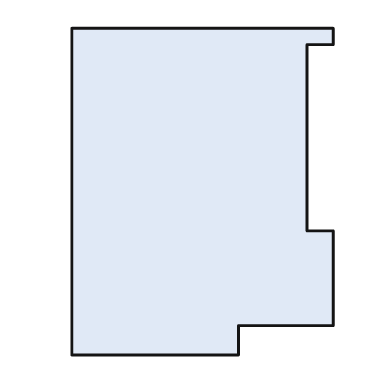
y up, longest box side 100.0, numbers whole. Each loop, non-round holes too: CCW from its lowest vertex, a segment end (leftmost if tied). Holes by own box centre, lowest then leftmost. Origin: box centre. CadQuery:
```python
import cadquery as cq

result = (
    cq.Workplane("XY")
    .moveTo(-40.0, -50.0)
    .lineTo(11.0, -50.0)
    .lineTo(11.0, -41.0)
    .lineTo(40.0, -41.0)
    .lineTo(40.0, -12.0)
    .lineTo(32.0, -12.0)
    .lineTo(32.0, 45.0)
    .lineTo(40.0, 45.0)
    .lineTo(40.0, 50.0)
    .lineTo(-40.0, 50.0)
    .close()
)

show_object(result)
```